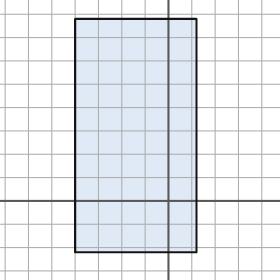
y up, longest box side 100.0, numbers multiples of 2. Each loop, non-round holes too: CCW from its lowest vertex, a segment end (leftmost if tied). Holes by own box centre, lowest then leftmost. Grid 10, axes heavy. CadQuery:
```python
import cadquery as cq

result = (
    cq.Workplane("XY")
    .moveTo(-40.0, -22.0)
    .lineTo(12.0, -22.0)
    .lineTo(12.0, 78.0)
    .lineTo(-40.0, 78.0)
    .close()
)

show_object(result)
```